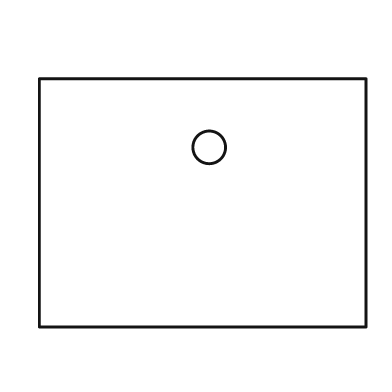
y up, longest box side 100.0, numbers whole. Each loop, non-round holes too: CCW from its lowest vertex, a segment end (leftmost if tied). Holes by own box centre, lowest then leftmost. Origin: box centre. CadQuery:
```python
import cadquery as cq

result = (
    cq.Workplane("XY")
    .moveTo(-50.0, -38.0)
    .lineTo(50.0, -38.0)
    .lineTo(50.0, 38.0)
    .lineTo(-50.0, 38.0)
    .close()
    .moveTo(2.0, 17.0)
    .circle(5.0)
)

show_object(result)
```